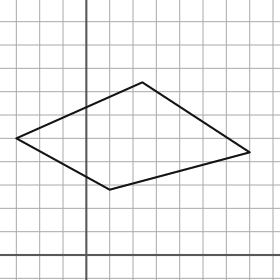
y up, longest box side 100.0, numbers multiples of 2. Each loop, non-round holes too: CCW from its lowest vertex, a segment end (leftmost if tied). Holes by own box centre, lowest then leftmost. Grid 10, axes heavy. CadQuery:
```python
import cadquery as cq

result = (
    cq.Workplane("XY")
    .moveTo(10.0, 28.0)
    .lineTo(70.0, 44.0)
    .lineTo(24.0, 74.0)
    .lineTo(-30.0, 50.0)
    .close()
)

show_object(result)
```